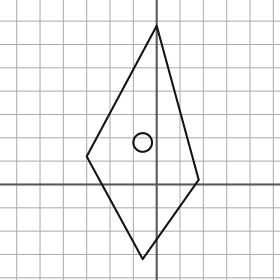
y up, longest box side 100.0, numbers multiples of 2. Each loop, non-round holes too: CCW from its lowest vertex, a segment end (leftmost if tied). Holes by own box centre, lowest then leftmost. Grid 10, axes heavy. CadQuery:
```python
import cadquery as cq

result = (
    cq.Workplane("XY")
    .moveTo(-6.0, -32.0)
    .lineTo(18.0, 2.0)
    .lineTo(0.0, 68.0)
    .lineTo(-30.0, 12.0)
    .close()
    .moveTo(-6.0, 18.0)
    .circle(4.0)
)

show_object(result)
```